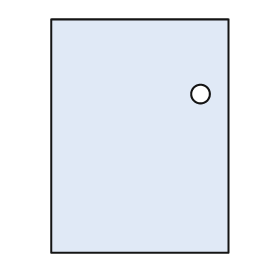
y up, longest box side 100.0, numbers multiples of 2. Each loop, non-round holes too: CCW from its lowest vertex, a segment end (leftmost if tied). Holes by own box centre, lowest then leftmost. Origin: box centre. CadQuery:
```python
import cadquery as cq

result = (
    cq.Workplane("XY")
    .moveTo(-38.0, -50.0)
    .lineTo(38.0, -50.0)
    .lineTo(38.0, 50.0)
    .lineTo(-38.0, 50.0)
    .close()
    .moveTo(26.0, 18.0)
    .circle(4.0)
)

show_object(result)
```